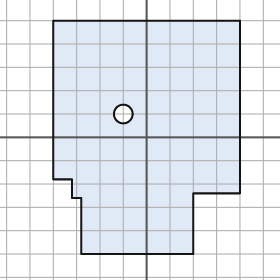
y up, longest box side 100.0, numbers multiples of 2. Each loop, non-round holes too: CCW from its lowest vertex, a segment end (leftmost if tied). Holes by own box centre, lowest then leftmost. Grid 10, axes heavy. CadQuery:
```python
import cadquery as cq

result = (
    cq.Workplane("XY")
    .moveTo(-28.0, -50.0)
    .lineTo(20.0, -50.0)
    .lineTo(20.0, -24.0)
    .lineTo(40.0, -24.0)
    .lineTo(40.0, 50.0)
    .lineTo(-40.0, 50.0)
    .lineTo(-40.0, -18.0)
    .lineTo(-32.0, -18.0)
    .lineTo(-32.0, -26.0)
    .lineTo(-28.0, -26.0)
    .close()
    .moveTo(-10.0, 10.0)
    .circle(4.0)
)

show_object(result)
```